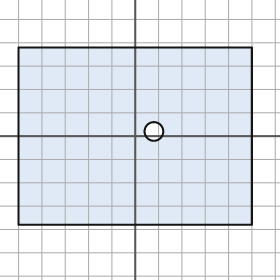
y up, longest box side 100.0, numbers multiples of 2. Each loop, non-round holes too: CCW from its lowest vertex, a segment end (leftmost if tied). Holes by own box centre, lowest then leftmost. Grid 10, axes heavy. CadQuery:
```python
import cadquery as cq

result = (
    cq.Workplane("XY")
    .moveTo(-50.0, -38.0)
    .lineTo(50.0, -38.0)
    .lineTo(50.0, 38.0)
    .lineTo(-50.0, 38.0)
    .close()
    .moveTo(8.0, 2.0)
    .circle(4.0)
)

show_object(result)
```